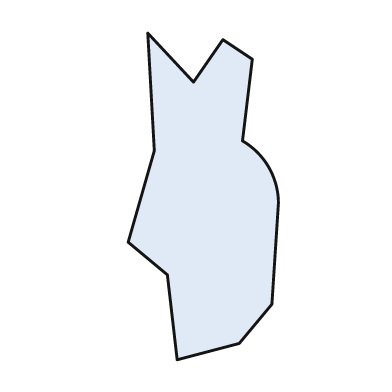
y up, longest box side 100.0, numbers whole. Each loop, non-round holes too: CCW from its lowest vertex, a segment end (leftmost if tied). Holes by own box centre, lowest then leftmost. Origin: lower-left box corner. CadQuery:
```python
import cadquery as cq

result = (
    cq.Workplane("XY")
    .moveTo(15.0, 0.0)
    .lineTo(34.0, 5.0)
    .lineTo(44.0, 17.0)
    .lineTo(46.0, 48.0)
    .threePointArc((43.0, 59.0), (35.0, 67.0))
    .lineTo(38.0, 92.0)
    .lineTo(29.0, 98.0)
    .lineTo(20.0, 85.0)
    .lineTo(6.0, 100.0)
    .lineTo(8.0, 64.0)
    .lineTo(0.0, 36.0)
    .lineTo(12.0, 26.0)
    .close()
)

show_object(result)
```